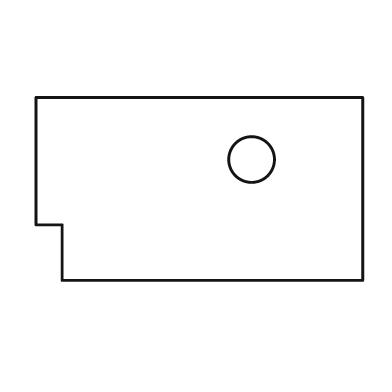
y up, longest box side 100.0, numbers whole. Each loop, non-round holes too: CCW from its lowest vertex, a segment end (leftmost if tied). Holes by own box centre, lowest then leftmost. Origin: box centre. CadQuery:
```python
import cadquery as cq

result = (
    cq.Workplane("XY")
    .moveTo(-42.0, -28.0)
    .lineTo(50.0, -28.0)
    .lineTo(50.0, 28.0)
    .lineTo(-50.0, 28.0)
    .lineTo(-50.0, -11.0)
    .lineTo(-42.0, -11.0)
    .close()
    .moveTo(16.0, 9.0)
    .circle(7.0)
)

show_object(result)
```